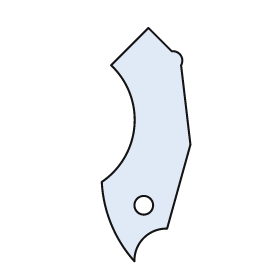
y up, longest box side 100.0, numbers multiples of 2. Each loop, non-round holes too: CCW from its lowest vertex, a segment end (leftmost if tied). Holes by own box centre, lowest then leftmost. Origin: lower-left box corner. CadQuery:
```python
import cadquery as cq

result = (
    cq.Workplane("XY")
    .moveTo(14.0, 0.0)
    .threePointArc((18.0, 10.0), (28.0, 14.0))
    .lineTo(38.0, 50.0)
    .lineTo(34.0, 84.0)
    .threePointArc((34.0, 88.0), (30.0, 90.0))
    .lineTo(20.0, 100.0)
    .lineTo(4.0, 84.0)
    .threePointArc((14.0, 58.0), (0.0, 34.0))
    .threePointArc((4.0, 16.0), (14.0, 0.0))
    .close()
    .moveTo(18.0, 24.0)
    .circle(4.0)
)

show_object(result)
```